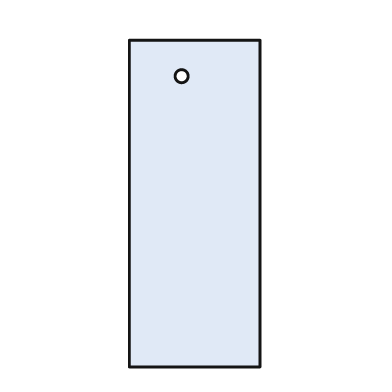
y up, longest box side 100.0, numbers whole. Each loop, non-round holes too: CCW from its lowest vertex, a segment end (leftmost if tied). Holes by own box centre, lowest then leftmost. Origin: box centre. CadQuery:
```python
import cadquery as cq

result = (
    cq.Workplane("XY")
    .moveTo(-20.0, -50.0)
    .lineTo(20.0, -50.0)
    .lineTo(20.0, 50.0)
    .lineTo(-20.0, 50.0)
    .close()
    .moveTo(-4.0, 39.0)
    .circle(2.0)
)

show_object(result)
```